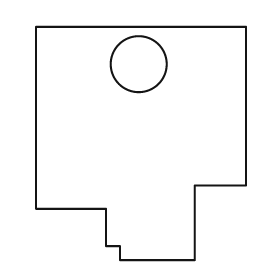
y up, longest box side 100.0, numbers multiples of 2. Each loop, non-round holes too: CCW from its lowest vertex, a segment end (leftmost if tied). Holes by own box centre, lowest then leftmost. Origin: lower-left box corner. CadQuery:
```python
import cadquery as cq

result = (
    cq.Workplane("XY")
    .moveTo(36.0, 0.0)
    .lineTo(68.0, 0.0)
    .lineTo(68.0, 32.0)
    .lineTo(90.0, 32.0)
    .lineTo(90.0, 100.0)
    .lineTo(0.0, 100.0)
    .lineTo(0.0, 22.0)
    .lineTo(30.0, 22.0)
    .lineTo(30.0, 6.0)
    .lineTo(36.0, 6.0)
    .close()
    .moveTo(44.0, 84.0)
    .circle(12.0)
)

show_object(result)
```